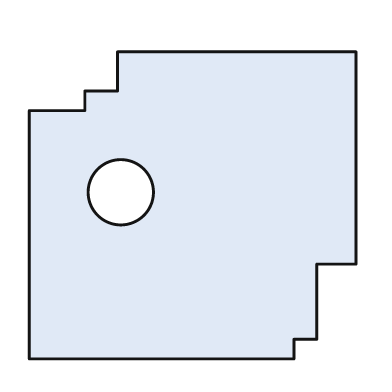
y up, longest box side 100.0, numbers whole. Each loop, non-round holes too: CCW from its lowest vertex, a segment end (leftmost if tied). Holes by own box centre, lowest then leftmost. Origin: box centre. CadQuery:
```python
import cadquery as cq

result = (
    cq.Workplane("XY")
    .moveTo(-50.0, -47.0)
    .lineTo(31.0, -47.0)
    .lineTo(31.0, -41.0)
    .lineTo(38.0, -41.0)
    .lineTo(38.0, -18.0)
    .lineTo(50.0, -18.0)
    .lineTo(50.0, 47.0)
    .lineTo(-23.0, 47.0)
    .lineTo(-23.0, 35.0)
    .lineTo(-33.0, 35.0)
    .lineTo(-33.0, 29.0)
    .lineTo(-50.0, 29.0)
    .close()
    .moveTo(-22.0, 4.0)
    .circle(10.0)
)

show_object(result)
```